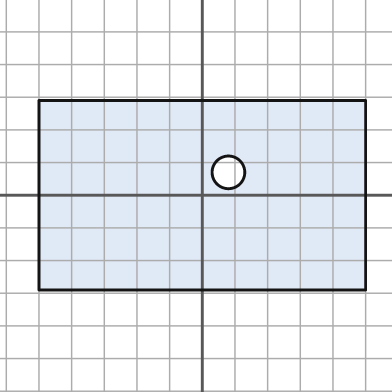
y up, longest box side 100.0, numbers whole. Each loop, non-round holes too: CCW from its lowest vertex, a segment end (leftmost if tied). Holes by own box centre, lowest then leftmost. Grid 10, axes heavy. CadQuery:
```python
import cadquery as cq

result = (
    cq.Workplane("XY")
    .moveTo(-50.0, -29.0)
    .lineTo(50.0, -29.0)
    .lineTo(50.0, 29.0)
    .lineTo(-50.0, 29.0)
    .close()
    .moveTo(8.0, 7.0)
    .circle(5.0)
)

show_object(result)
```